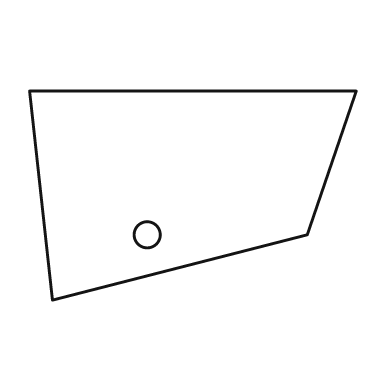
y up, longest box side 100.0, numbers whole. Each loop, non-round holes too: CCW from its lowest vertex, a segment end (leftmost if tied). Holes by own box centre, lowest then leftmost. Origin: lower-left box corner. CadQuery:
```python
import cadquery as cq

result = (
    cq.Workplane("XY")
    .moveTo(7.0, 0.0)
    .lineTo(85.0, 20.0)
    .lineTo(100.0, 64.0)
    .lineTo(0.0, 64.0)
    .close()
    .moveTo(36.0, 20.0)
    .circle(4.0)
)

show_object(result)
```